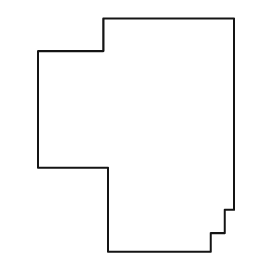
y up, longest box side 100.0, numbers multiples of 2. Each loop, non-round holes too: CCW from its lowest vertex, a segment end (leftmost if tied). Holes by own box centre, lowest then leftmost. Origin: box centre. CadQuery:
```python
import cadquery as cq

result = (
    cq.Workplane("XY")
    .moveTo(-12.0, -50.0)
    .lineTo(32.0, -50.0)
    .lineTo(32.0, -42.0)
    .lineTo(38.0, -42.0)
    .lineTo(38.0, -32.0)
    .lineTo(42.0, -32.0)
    .lineTo(42.0, 50.0)
    .lineTo(-14.0, 50.0)
    .lineTo(-14.0, 36.0)
    .lineTo(-42.0, 36.0)
    .lineTo(-42.0, -14.0)
    .lineTo(-12.0, -14.0)
    .close()
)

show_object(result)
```